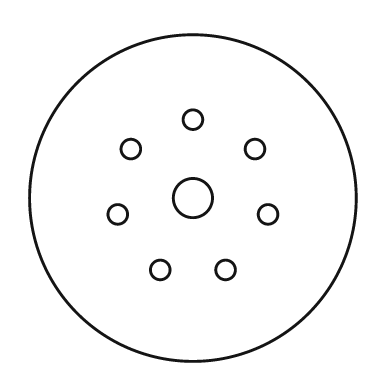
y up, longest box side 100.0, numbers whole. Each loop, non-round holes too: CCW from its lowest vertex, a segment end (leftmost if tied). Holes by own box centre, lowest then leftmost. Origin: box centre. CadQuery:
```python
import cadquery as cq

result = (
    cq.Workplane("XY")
    .moveTo(0.0, 0.0)
    .circle(50.0)
    .moveTo(-10.0, -22.0)
    .circle(3.0)
    .moveTo(10.0, -22.0)
    .circle(3.0)
    .moveTo(-23.0, -5.0)
    .circle(3.0)
    .moveTo(23.0, -5.0)
    .circle(3.0)
    .moveTo(0.0, 0.0)
    .circle(6.0)
    .moveTo(-19.0, 15.0)
    .circle(3.0)
    .moveTo(19.0, 15.0)
    .circle(3.0)
    .moveTo(0.0, 24.0)
    .circle(3.0)
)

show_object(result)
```